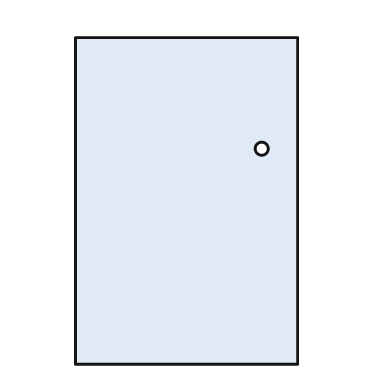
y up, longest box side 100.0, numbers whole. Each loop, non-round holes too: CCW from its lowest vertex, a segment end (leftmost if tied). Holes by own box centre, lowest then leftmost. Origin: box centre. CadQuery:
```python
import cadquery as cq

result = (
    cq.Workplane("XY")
    .moveTo(-34.0, -50.0)
    .lineTo(34.0, -50.0)
    .lineTo(34.0, 50.0)
    .lineTo(-34.0, 50.0)
    .close()
    .moveTo(23.0, 16.0)
    .circle(2.0)
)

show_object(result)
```